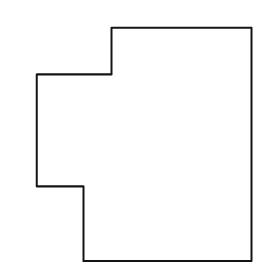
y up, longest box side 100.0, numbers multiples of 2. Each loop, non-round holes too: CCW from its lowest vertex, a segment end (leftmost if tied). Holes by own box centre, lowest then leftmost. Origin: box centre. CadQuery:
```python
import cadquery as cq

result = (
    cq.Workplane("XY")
    .moveTo(-26.0, -50.0)
    .lineTo(46.0, -50.0)
    .lineTo(46.0, 50.0)
    .lineTo(-14.0, 50.0)
    .lineTo(-14.0, 30.0)
    .lineTo(-46.0, 30.0)
    .lineTo(-46.0, -18.0)
    .lineTo(-26.0, -18.0)
    .close()
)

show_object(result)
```